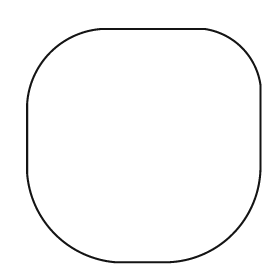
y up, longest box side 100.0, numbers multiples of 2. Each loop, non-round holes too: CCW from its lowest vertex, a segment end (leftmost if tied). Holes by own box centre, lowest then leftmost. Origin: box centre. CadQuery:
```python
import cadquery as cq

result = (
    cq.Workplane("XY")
    .moveTo(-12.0, -50.0)
    .lineTo(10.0, -50.0)
    .threePointArc((38.0, -38.0), (50.0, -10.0))
    .lineTo(50.0, 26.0)
    .threePointArc((42.0, 42.0), (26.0, 50.0))
    .lineTo(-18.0, 50.0)
    .threePointArc((-40.0, 40.0), (-50.0, 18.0))
    .lineTo(-50.0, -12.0)
    .threePointArc((-38.0, -38.0), (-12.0, -50.0))
    .close()
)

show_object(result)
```